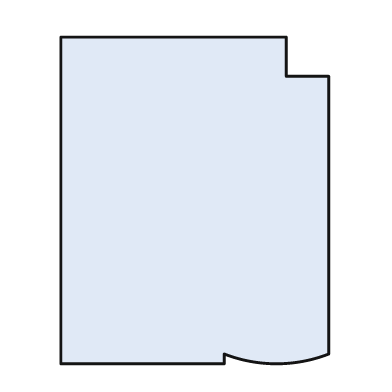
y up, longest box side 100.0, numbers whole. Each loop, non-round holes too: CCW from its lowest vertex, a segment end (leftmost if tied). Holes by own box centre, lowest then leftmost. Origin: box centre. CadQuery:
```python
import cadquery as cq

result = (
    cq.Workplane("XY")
    .moveTo(-41.0, -50.0)
    .lineTo(9.0, -50.0)
    .lineTo(9.0, -47.0)
    .threePointArc((25.0, -50.0), (41.0, -47.0))
    .lineTo(41.0, 38.0)
    .lineTo(28.0, 38.0)
    .lineTo(28.0, 50.0)
    .lineTo(-41.0, 50.0)
    .close()
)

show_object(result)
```